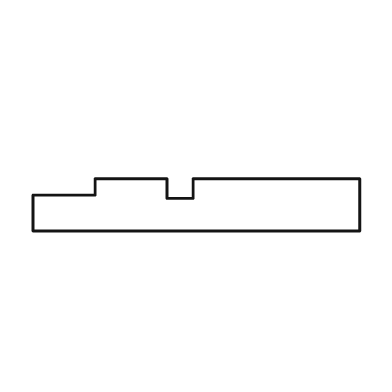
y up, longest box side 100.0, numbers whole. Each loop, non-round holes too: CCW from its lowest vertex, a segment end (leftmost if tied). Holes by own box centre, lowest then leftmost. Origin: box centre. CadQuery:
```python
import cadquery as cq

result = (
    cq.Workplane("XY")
    .moveTo(-50.0, -8.0)
    .lineTo(50.0, -8.0)
    .lineTo(50.0, 8.0)
    .lineTo(-1.0, 8.0)
    .lineTo(-1.0, 2.0)
    .lineTo(-9.0, 2.0)
    .lineTo(-9.0, 8.0)
    .lineTo(-31.0, 8.0)
    .lineTo(-31.0, 3.0)
    .lineTo(-50.0, 3.0)
    .close()
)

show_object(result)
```